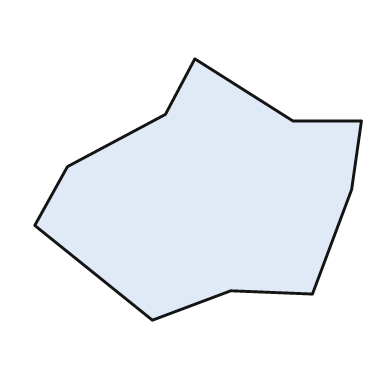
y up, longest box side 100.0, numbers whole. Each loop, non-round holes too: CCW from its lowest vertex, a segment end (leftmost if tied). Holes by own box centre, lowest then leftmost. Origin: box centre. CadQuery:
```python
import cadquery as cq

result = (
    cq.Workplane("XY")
    .moveTo(-14.0, -40.0)
    .lineTo(10.0, -31.0)
    .lineTo(35.0, -32.0)
    .lineTo(47.0, 0.0)
    .lineTo(50.0, 21.0)
    .lineTo(29.0, 21.0)
    .lineTo(-1.0, 40.0)
    .lineTo(-10.0, 23.0)
    .lineTo(-40.0, 7.0)
    .lineTo(-50.0, -11.0)
    .close()
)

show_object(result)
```